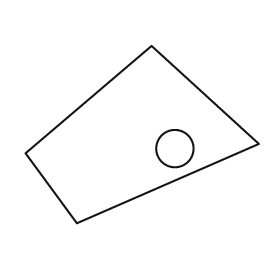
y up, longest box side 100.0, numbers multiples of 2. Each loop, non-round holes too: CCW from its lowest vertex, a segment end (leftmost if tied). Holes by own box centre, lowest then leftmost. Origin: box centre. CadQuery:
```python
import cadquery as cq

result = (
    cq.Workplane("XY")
    .moveTo(-28.0, -38.0)
    .lineTo(50.0, -4.0)
    .lineTo(4.0, 38.0)
    .lineTo(-50.0, -8.0)
    .close()
    .moveTo(14.0, -6.0)
    .circle(8.0)
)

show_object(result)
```